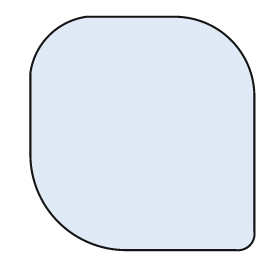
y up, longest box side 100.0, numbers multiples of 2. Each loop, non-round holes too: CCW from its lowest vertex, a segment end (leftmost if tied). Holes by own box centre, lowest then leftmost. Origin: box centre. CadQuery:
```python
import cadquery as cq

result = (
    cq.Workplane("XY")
    .moveTo(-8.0, -50.0)
    .lineTo(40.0, -50.0)
    .threePointArc((46.0, -48.0), (48.0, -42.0))
    .lineTo(48.0, 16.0)
    .threePointArc((38.0, 40.0), (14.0, 50.0))
    .lineTo(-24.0, 50.0)
    .threePointArc((-40.0, 42.0), (-48.0, 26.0))
    .lineTo(-48.0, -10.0)
    .threePointArc((-36.0, -38.0), (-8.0, -50.0))
    .close()
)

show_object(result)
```